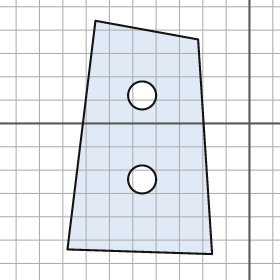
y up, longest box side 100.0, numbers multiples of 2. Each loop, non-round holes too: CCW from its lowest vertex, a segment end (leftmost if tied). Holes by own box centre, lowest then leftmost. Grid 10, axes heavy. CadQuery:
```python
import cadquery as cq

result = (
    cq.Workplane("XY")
    .moveTo(-16.0, -56.0)
    .lineTo(-22.0, 36.0)
    .lineTo(-66.0, 44.0)
    .lineTo(-78.0, -54.0)
    .close()
    .moveTo(-46.0, -24.0)
    .circle(6.0)
    .moveTo(-46.0, 12.0)
    .circle(6.0)
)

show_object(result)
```